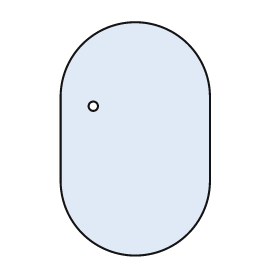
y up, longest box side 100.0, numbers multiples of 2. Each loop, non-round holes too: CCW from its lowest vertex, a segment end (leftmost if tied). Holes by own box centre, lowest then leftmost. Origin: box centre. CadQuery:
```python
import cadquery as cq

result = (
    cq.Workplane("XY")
    .moveTo(-32.0, -18.0)
    .threePointArc((0.0, -50.0), (32.0, -18.0))
    .lineTo(32.0, 18.0)
    .threePointArc((0.0, 50.0), (-32.0, 18.0))
    .close()
    .moveTo(-18.0, 14.0)
    .circle(2.0)
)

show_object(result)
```